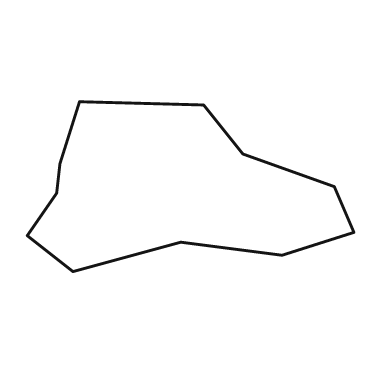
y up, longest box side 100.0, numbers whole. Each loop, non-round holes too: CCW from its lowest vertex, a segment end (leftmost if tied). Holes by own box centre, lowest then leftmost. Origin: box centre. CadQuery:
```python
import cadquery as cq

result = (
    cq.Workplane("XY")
    .moveTo(-36.0, -26.0)
    .lineTo(-3.0, -17.0)
    .lineTo(28.0, -21.0)
    .lineTo(50.0, -14.0)
    .lineTo(44.0, 0.0)
    .lineTo(16.0, 10.0)
    .lineTo(4.0, 25.0)
    .lineTo(-34.0, 26.0)
    .lineTo(-40.0, 7.0)
    .lineTo(-41.0, -2.0)
    .lineTo(-50.0, -15.0)
    .close()
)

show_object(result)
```